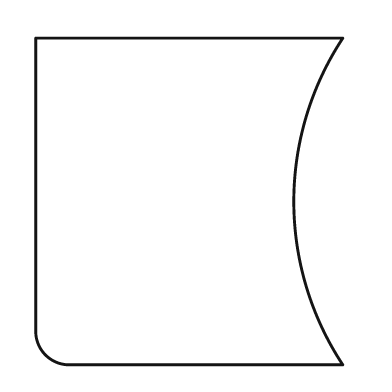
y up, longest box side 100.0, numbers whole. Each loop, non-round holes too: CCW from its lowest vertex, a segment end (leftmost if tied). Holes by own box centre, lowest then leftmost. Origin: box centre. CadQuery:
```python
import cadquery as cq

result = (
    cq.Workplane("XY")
    .moveTo(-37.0, -50.0)
    .lineTo(47.0, -50.0)
    .threePointArc((32.0, 0.0), (47.0, 50.0))
    .lineTo(-47.0, 50.0)
    .lineTo(-47.0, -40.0)
    .threePointArc((-44.0, -47.0), (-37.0, -50.0))
    .close()
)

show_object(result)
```